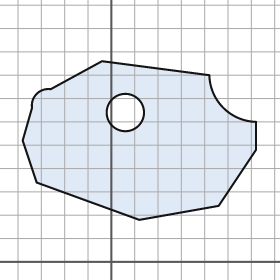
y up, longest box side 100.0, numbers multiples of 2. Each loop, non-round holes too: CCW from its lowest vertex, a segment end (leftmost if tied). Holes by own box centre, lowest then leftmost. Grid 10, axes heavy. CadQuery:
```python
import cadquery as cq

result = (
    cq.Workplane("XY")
    .moveTo(12.0, 18.0)
    .lineTo(46.0, 24.0)
    .lineTo(62.0, 48.0)
    .lineTo(62.0, 60.0)
    .threePointArc((48.0, 66.0), (42.0, 80.0))
    .lineTo(-4.0, 86.0)
    .lineTo(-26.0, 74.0)
    .threePointArc((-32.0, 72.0), (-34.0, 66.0))
    .lineTo(-38.0, 52.0)
    .lineTo(-32.0, 34.0)
    .close()
    .moveTo(6.0, 64.0)
    .circle(8.0)
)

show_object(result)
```